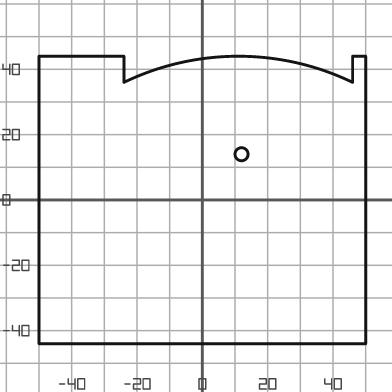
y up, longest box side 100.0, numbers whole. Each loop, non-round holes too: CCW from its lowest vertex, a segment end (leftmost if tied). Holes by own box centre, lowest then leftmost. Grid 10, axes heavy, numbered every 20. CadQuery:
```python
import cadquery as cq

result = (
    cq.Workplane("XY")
    .moveTo(-50.0, -44.0)
    .lineTo(50.0, -44.0)
    .lineTo(50.0, 44.0)
    .lineTo(46.0, 44.0)
    .lineTo(46.0, 36.0)
    .threePointArc((11.0, 44.0), (-24.0, 36.0))
    .lineTo(-24.0, 44.0)
    .lineTo(-50.0, 44.0)
    .close()
    .moveTo(12.0, 14.0)
    .circle(2.0)
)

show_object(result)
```